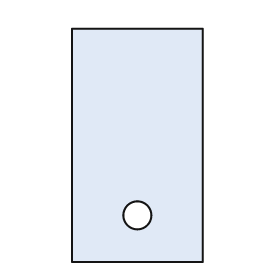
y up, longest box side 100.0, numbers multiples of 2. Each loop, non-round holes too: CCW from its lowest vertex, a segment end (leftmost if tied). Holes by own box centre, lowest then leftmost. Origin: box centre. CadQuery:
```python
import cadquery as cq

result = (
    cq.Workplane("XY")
    .moveTo(-28.0, -50.0)
    .lineTo(28.0, -50.0)
    .lineTo(28.0, 50.0)
    .lineTo(-28.0, 50.0)
    .close()
    .moveTo(0.0, -30.0)
    .circle(6.0)
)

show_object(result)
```